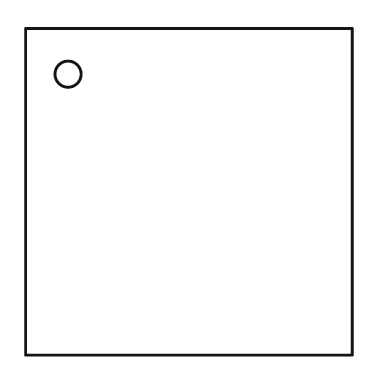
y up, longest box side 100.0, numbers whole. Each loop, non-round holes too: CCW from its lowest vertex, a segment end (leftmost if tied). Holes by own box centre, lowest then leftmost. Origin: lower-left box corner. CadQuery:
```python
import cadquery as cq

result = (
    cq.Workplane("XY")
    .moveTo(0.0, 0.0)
    .lineTo(100.0, 0.0)
    .lineTo(100.0, 100.0)
    .lineTo(0.0, 100.0)
    .close()
    .moveTo(13.0, 86.0)
    .circle(4.0)
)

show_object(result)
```